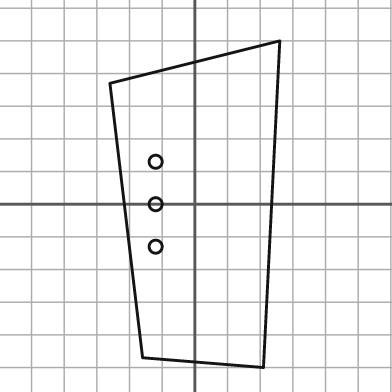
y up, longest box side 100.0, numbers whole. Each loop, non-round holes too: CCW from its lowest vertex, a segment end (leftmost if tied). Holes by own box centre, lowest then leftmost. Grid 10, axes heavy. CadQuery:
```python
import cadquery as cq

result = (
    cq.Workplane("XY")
    .moveTo(21.0, -50.0)
    .lineTo(26.0, 50.0)
    .lineTo(-26.0, 37.0)
    .lineTo(-16.0, -47.0)
    .close()
    .moveTo(-12.0, -13.0)
    .circle(2.0)
    .moveTo(-12.0, 0.0)
    .circle(2.0)
    .moveTo(-12.0, 13.0)
    .circle(2.0)
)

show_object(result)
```